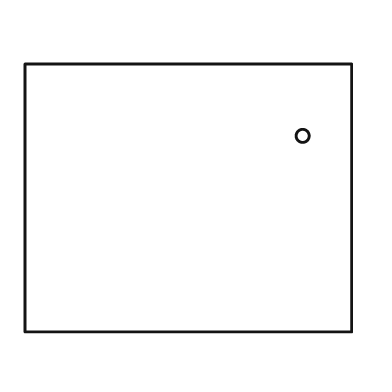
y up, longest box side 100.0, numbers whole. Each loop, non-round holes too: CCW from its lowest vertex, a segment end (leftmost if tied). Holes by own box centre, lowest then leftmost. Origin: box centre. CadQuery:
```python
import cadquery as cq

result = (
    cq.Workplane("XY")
    .moveTo(-50.0, -41.0)
    .lineTo(50.0, -41.0)
    .lineTo(50.0, 41.0)
    .lineTo(-50.0, 41.0)
    .close()
    .moveTo(35.0, 19.0)
    .circle(2.0)
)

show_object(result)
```